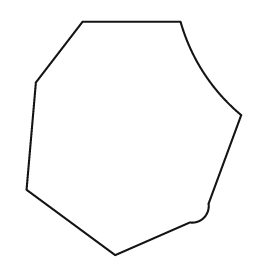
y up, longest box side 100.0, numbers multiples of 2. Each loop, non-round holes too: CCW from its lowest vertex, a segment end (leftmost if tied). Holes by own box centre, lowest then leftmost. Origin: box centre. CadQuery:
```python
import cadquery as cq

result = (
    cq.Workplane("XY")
    .moveTo(-8.0, -50.0)
    .lineTo(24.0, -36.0)
    .threePointArc((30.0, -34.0), (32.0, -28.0))
    .lineTo(46.0, 10.0)
    .threePointArc((30.0, 28.0), (20.0, 50.0))
    .lineTo(-22.0, 50.0)
    .lineTo(-42.0, 24.0)
    .lineTo(-46.0, -22.0)
    .close()
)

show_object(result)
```